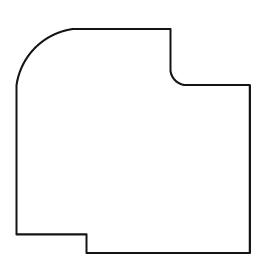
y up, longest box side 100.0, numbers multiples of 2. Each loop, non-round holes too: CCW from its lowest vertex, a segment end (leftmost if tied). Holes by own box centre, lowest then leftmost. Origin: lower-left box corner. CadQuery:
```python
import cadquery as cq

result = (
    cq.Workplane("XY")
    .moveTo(30.0, 0.0)
    .lineTo(100.0, 0.0)
    .lineTo(100.0, 72.0)
    .lineTo(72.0, 72.0)
    .threePointArc((68.0, 74.0), (66.0, 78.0))
    .lineTo(66.0, 96.0)
    .lineTo(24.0, 96.0)
    .threePointArc((8.0, 88.0), (0.0, 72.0))
    .lineTo(0.0, 8.0)
    .lineTo(30.0, 8.0)
    .close()
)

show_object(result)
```